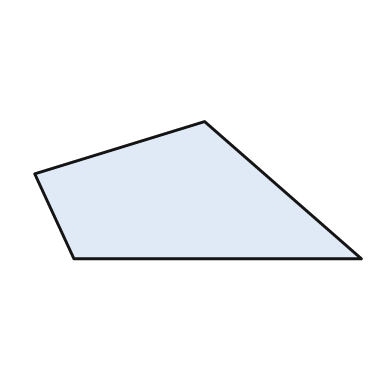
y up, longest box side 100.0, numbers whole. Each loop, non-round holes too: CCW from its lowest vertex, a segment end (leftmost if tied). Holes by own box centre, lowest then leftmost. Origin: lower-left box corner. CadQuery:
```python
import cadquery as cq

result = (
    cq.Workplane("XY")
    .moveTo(12.0, 0.0)
    .lineTo(100.0, 0.0)
    .lineTo(52.0, 42.0)
    .lineTo(0.0, 26.0)
    .close()
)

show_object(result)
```